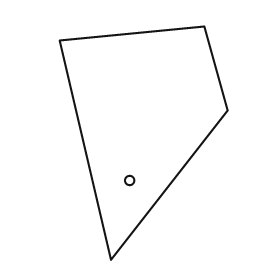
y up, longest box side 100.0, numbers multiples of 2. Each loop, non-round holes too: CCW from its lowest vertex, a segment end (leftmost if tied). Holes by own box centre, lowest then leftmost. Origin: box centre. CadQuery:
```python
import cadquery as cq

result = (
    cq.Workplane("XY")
    .moveTo(-14.0, -50.0)
    .lineTo(36.0, 14.0)
    .lineTo(26.0, 50.0)
    .lineTo(-36.0, 44.0)
    .close()
    .moveTo(-6.0, -16.0)
    .circle(2.0)
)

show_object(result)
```